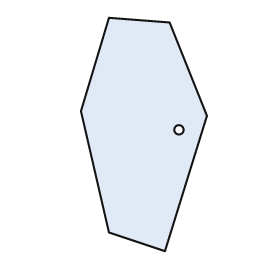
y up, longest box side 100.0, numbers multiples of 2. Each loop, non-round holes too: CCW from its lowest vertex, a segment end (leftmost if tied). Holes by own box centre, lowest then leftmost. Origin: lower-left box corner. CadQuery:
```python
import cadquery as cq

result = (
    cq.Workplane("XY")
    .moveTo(36.0, 0.0)
    .lineTo(54.0, 58.0)
    .lineTo(38.0, 98.0)
    .lineTo(12.0, 100.0)
    .lineTo(0.0, 60.0)
    .lineTo(12.0, 8.0)
    .close()
    .moveTo(42.0, 52.0)
    .circle(2.0)
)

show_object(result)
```